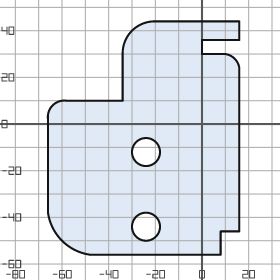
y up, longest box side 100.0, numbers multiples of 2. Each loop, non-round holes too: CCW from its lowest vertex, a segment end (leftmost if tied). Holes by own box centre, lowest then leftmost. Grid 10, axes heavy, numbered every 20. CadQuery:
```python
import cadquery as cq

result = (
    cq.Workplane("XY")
    .moveTo(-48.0, -56.0)
    .lineTo(8.0, -56.0)
    .lineTo(8.0, -46.0)
    .lineTo(16.0, -46.0)
    .lineTo(16.0, 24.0)
    .threePointArc((14.0, 28.0), (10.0, 30.0))
    .lineTo(0.0, 30.0)
    .lineTo(0.0, 36.0)
    .lineTo(16.0, 36.0)
    .lineTo(16.0, 44.0)
    .lineTo(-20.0, 44.0)
    .threePointArc((-30.0, 40.0), (-34.0, 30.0))
    .lineTo(-34.0, 10.0)
    .lineTo(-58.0, 10.0)
    .threePointArc((-64.0, 8.0), (-66.0, 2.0))
    .lineTo(-66.0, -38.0)
    .threePointArc((-60.0, -50.0), (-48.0, -56.0))
    .close()
    .moveTo(-24.0, -44.0)
    .circle(6.0)
    .moveTo(-24.0, -12.0)
    .circle(6.0)
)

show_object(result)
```